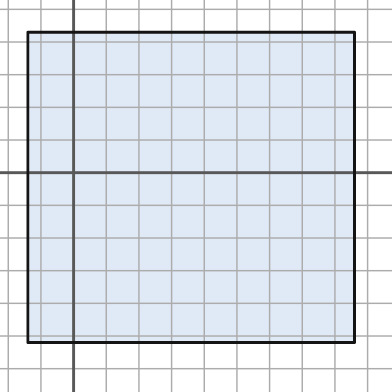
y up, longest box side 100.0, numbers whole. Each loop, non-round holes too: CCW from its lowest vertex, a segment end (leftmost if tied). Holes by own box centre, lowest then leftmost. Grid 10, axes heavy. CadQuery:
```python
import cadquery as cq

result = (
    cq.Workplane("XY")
    .moveTo(-14.0, -52.0)
    .lineTo(86.0, -52.0)
    .lineTo(86.0, 43.0)
    .lineTo(-14.0, 43.0)
    .close()
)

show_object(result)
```